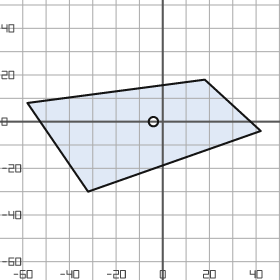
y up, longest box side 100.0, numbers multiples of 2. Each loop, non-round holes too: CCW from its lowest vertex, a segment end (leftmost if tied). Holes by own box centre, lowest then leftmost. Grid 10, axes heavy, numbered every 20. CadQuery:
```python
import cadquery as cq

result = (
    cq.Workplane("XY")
    .moveTo(-32.0, -30.0)
    .lineTo(42.0, -4.0)
    .lineTo(18.0, 18.0)
    .lineTo(-58.0, 8.0)
    .close()
    .moveTo(-4.0, 0.0)
    .circle(2.0)
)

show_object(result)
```